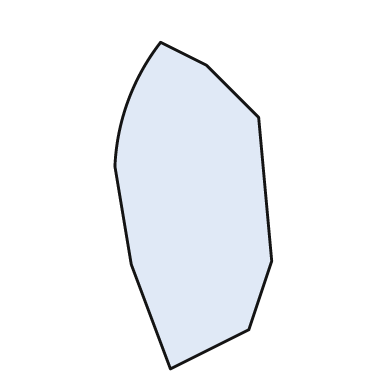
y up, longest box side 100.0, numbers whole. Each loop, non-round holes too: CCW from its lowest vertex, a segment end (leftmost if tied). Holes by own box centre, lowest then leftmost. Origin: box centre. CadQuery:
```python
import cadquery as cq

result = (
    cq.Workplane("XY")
    .moveTo(-7.0, -50.0)
    .lineTo(17.0, -38.0)
    .lineTo(24.0, -17.0)
    .lineTo(20.0, 27.0)
    .lineTo(4.0, 43.0)
    .lineTo(-10.0, 50.0)
    .threePointArc((-20.0, 32.0), (-24.0, 12.0))
    .lineTo(-19.0, -18.0)
    .close()
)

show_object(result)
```